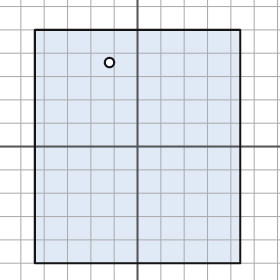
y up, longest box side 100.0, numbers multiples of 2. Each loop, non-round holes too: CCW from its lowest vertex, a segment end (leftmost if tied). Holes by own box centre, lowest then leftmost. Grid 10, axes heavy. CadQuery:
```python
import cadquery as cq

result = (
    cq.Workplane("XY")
    .moveTo(-44.0, -50.0)
    .lineTo(44.0, -50.0)
    .lineTo(44.0, 50.0)
    .lineTo(-44.0, 50.0)
    .close()
    .moveTo(-12.0, 36.0)
    .circle(2.0)
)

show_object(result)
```